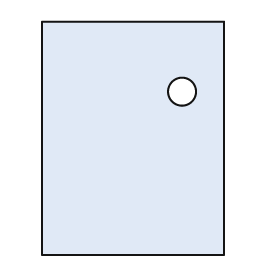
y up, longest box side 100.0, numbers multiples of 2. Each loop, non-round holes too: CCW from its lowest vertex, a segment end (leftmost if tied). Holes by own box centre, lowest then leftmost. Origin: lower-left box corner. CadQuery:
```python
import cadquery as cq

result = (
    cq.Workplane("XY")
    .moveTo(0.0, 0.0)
    .lineTo(78.0, 0.0)
    .lineTo(78.0, 100.0)
    .lineTo(0.0, 100.0)
    .close()
    .moveTo(60.0, 70.0)
    .circle(6.0)
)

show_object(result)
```